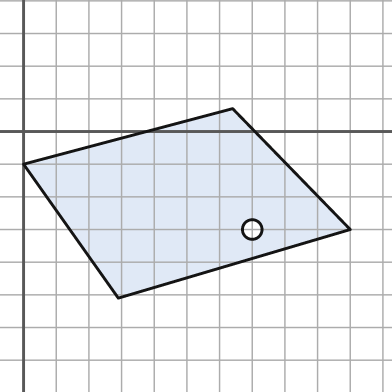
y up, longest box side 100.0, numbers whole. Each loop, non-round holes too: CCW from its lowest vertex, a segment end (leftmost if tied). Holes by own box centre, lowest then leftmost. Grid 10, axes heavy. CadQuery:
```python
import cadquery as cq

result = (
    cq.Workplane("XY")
    .moveTo(29.0, -51.0)
    .lineTo(100.0, -30.0)
    .lineTo(64.0, 7.0)
    .lineTo(0.0, -10.0)
    .close()
    .moveTo(70.0, -30.0)
    .circle(3.0)
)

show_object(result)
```